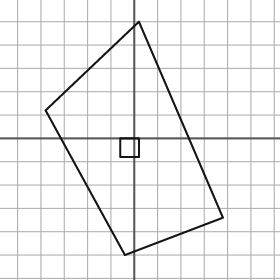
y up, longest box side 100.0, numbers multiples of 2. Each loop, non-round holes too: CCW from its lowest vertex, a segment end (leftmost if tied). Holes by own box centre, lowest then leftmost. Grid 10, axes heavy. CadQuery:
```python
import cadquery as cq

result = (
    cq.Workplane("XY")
    .moveTo(-4.0, -50.0)
    .lineTo(38.0, -34.0)
    .lineTo(2.0, 50.0)
    .lineTo(-38.0, 12.0)
    .close()
    .moveTo(-6.0, -8.0)
    .lineTo(2.0, -8.0)
    .lineTo(2.0, 0.0)
    .lineTo(-6.0, 0.0)
    .close()
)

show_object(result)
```